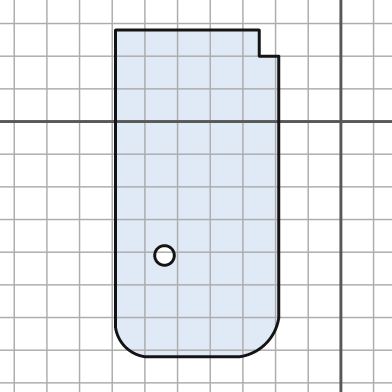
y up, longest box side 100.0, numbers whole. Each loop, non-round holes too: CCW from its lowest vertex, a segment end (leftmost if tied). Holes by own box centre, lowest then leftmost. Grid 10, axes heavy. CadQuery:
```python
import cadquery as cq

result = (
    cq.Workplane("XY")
    .moveTo(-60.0, -72.0)
    .lineTo(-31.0, -72.0)
    .threePointArc((-23.0, -68.0), (-19.0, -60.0))
    .lineTo(-19.0, 20.0)
    .lineTo(-25.0, 20.0)
    .lineTo(-25.0, 28.0)
    .lineTo(-69.0, 28.0)
    .lineTo(-69.0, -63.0)
    .threePointArc((-66.0, -69.0), (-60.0, -72.0))
    .close()
    .moveTo(-54.0, -41.0)
    .circle(3.0)
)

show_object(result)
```